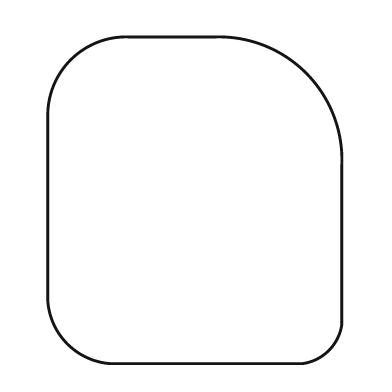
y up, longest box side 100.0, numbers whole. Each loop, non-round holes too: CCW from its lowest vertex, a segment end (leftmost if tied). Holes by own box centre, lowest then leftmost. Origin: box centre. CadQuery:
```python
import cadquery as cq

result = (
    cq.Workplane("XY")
    .moveTo(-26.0, -50.0)
    .lineTo(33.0, -50.0)
    .threePointArc((41.0, -46.0), (45.0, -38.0))
    .lineTo(45.0, 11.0)
    .threePointArc((34.0, 39.0), (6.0, 50.0))
    .lineTo(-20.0, 50.0)
    .threePointArc((-38.0, 43.0), (-45.0, 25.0))
    .lineTo(-45.0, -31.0)
    .threePointArc((-39.0, -44.0), (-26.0, -50.0))
    .close()
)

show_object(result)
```